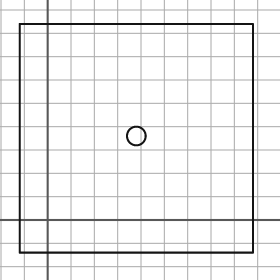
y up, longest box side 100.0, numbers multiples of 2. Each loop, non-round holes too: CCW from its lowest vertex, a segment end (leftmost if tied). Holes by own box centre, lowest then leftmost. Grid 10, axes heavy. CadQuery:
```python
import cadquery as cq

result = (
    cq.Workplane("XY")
    .moveTo(-12.0, -14.0)
    .lineTo(88.0, -14.0)
    .lineTo(88.0, 84.0)
    .lineTo(-12.0, 84.0)
    .close()
    .moveTo(38.0, 36.0)
    .circle(4.0)
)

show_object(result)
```